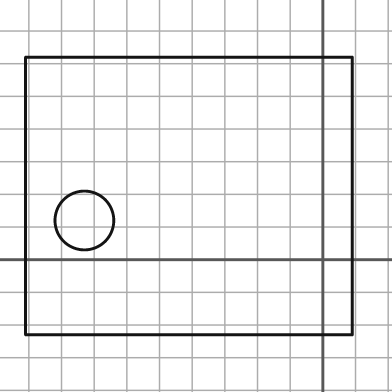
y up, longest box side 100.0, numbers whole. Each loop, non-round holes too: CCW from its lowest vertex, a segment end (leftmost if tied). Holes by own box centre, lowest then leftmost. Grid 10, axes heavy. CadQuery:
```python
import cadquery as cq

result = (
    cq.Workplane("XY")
    .moveTo(-91.0, -23.0)
    .lineTo(9.0, -23.0)
    .lineTo(9.0, 62.0)
    .lineTo(-91.0, 62.0)
    .close()
    .moveTo(-73.0, 12.0)
    .circle(9.0)
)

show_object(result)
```